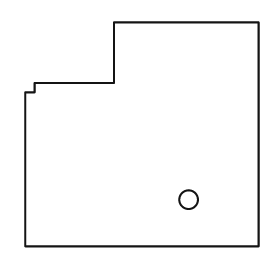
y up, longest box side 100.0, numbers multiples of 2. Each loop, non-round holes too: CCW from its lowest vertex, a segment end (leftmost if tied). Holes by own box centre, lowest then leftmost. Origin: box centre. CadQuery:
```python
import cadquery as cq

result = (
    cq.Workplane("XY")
    .moveTo(-50.0, -48.0)
    .lineTo(50.0, -48.0)
    .lineTo(50.0, 48.0)
    .lineTo(-12.0, 48.0)
    .lineTo(-12.0, 22.0)
    .lineTo(-46.0, 22.0)
    .lineTo(-46.0, 18.0)
    .lineTo(-50.0, 18.0)
    .close()
    .moveTo(20.0, -28.0)
    .circle(4.0)
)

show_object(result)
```